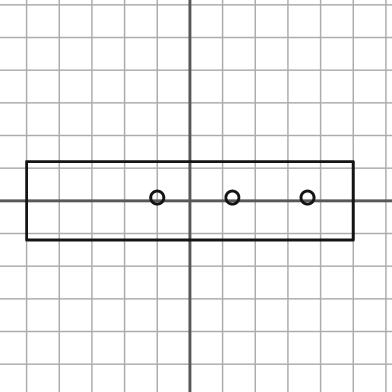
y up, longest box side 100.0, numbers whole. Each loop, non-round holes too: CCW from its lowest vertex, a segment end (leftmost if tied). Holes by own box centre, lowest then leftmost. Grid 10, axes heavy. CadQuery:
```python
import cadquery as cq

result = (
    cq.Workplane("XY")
    .moveTo(-50.0, -12.0)
    .lineTo(50.0, -12.0)
    .lineTo(50.0, 12.0)
    .lineTo(-50.0, 12.0)
    .close()
    .moveTo(-10.0, 1.0)
    .circle(2.0)
    .moveTo(13.0, 1.0)
    .circle(2.0)
    .moveTo(36.0, 1.0)
    .circle(2.0)
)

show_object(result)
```